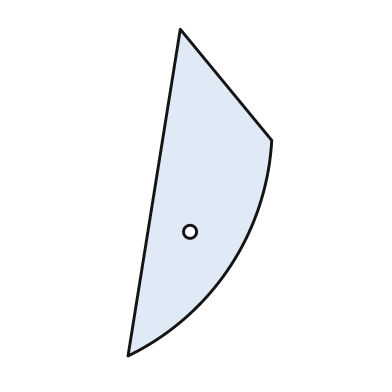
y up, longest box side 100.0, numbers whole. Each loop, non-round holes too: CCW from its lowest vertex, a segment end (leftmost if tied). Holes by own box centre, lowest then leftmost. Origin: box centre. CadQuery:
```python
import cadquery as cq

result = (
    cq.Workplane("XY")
    .moveTo(-22.0, -50.0)
    .threePointArc((9.0, -23.0), (22.0, 16.0))
    .lineTo(-6.0, 50.0)
    .close()
    .moveTo(-3.0, -12.0)
    .circle(2.0)
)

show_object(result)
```